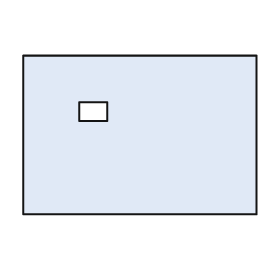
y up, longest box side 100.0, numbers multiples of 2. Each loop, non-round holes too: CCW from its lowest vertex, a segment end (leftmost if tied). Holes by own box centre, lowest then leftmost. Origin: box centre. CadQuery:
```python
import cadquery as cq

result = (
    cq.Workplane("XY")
    .moveTo(-50.0, -34.0)
    .lineTo(50.0, -34.0)
    .lineTo(50.0, 34.0)
    .lineTo(-50.0, 34.0)
    .close()
    .moveTo(-26.0, 6.0)
    .lineTo(-14.0, 6.0)
    .lineTo(-14.0, 14.0)
    .lineTo(-26.0, 14.0)
    .close()
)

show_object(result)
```